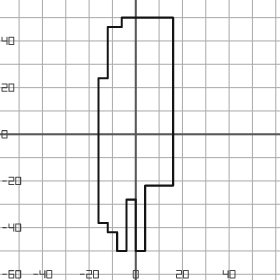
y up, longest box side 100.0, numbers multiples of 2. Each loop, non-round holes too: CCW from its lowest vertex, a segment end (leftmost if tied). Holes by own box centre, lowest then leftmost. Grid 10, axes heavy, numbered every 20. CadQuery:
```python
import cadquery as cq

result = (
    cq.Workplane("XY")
    .moveTo(-8.0, -50.0)
    .lineTo(-4.0, -50.0)
    .lineTo(-4.0, -28.0)
    .lineTo(0.0, -28.0)
    .lineTo(0.0, -50.0)
    .lineTo(4.0, -50.0)
    .lineTo(4.0, -22.0)
    .lineTo(16.0, -22.0)
    .lineTo(16.0, 50.0)
    .lineTo(-6.0, 50.0)
    .lineTo(-6.0, 46.0)
    .lineTo(-12.0, 46.0)
    .lineTo(-12.0, 24.0)
    .lineTo(-16.0, 24.0)
    .lineTo(-16.0, -38.0)
    .lineTo(-12.0, -38.0)
    .lineTo(-12.0, -42.0)
    .lineTo(-8.0, -42.0)
    .close()
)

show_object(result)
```